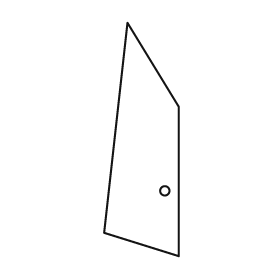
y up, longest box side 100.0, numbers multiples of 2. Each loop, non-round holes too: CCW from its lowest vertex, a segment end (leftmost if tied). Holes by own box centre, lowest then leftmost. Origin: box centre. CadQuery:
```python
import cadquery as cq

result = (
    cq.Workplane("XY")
    .moveTo(16.0, -50.0)
    .lineTo(16.0, 14.0)
    .lineTo(-6.0, 50.0)
    .lineTo(-16.0, -40.0)
    .close()
    .moveTo(10.0, -22.0)
    .circle(2.0)
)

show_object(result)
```